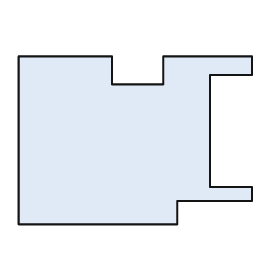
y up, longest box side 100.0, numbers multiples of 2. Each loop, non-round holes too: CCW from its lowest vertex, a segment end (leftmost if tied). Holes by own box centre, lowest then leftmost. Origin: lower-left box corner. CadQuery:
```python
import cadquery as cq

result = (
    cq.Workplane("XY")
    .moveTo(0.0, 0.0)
    .lineTo(68.0, 0.0)
    .lineTo(68.0, 10.0)
    .lineTo(100.0, 10.0)
    .lineTo(100.0, 16.0)
    .lineTo(82.0, 16.0)
    .lineTo(82.0, 64.0)
    .lineTo(100.0, 64.0)
    .lineTo(100.0, 72.0)
    .lineTo(62.0, 72.0)
    .lineTo(62.0, 60.0)
    .lineTo(40.0, 60.0)
    .lineTo(40.0, 72.0)
    .lineTo(0.0, 72.0)
    .close()
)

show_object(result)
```